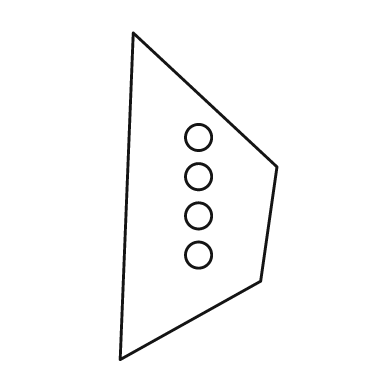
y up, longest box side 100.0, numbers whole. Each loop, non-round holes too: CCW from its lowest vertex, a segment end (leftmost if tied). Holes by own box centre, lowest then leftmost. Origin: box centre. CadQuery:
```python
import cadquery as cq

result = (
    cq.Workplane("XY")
    .moveTo(-24.0, -50.0)
    .lineTo(19.0, -26.0)
    .lineTo(24.0, 9.0)
    .lineTo(-20.0, 50.0)
    .close()
    .moveTo(0.0, -18.0)
    .circle(4.0)
    .moveTo(0.0, -6.0)
    .circle(4.0)
    .moveTo(0.0, 6.0)
    .circle(4.0)
    .moveTo(0.0, 18.0)
    .circle(4.0)
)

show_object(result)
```